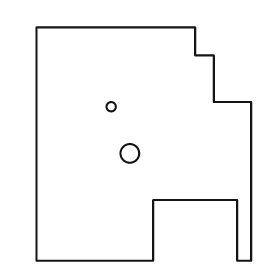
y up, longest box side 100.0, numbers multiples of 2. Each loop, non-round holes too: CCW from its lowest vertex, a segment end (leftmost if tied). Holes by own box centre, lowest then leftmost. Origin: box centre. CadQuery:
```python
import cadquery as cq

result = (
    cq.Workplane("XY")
    .moveTo(-46.0, -50.0)
    .lineTo(4.0, -50.0)
    .lineTo(4.0, -24.0)
    .lineTo(40.0, -24.0)
    .lineTo(40.0, -50.0)
    .lineTo(46.0, -50.0)
    .lineTo(46.0, 18.0)
    .lineTo(30.0, 18.0)
    .lineTo(30.0, 38.0)
    .lineTo(22.0, 38.0)
    .lineTo(22.0, 50.0)
    .lineTo(-46.0, 50.0)
    .close()
    .moveTo(-6.0, -4.0)
    .circle(4.0)
    .moveTo(-14.0, 16.0)
    .circle(2.0)
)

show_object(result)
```